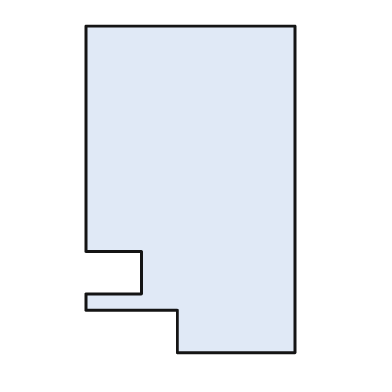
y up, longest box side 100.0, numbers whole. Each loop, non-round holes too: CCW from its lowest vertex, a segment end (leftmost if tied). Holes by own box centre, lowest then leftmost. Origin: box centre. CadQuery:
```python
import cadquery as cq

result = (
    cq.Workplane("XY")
    .moveTo(-4.0, -50.0)
    .lineTo(32.0, -50.0)
    .lineTo(32.0, 50.0)
    .lineTo(-32.0, 50.0)
    .lineTo(-32.0, -19.0)
    .lineTo(-15.0, -19.0)
    .lineTo(-15.0, -32.0)
    .lineTo(-32.0, -32.0)
    .lineTo(-32.0, -37.0)
    .lineTo(-4.0, -37.0)
    .close()
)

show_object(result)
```